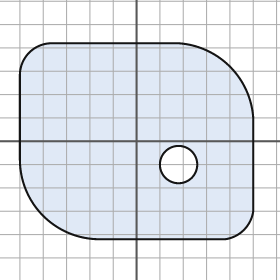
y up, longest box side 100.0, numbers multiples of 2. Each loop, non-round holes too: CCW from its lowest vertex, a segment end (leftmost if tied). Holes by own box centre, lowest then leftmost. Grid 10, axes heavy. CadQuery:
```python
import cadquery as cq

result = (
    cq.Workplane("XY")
    .moveTo(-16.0, -42.0)
    .lineTo(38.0, -42.0)
    .threePointArc((46.0, -38.0), (50.0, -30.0))
    .lineTo(50.0, 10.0)
    .threePointArc((40.0, 32.0), (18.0, 42.0))
    .lineTo(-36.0, 42.0)
    .threePointArc((-46.0, 38.0), (-50.0, 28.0))
    .lineTo(-50.0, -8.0)
    .threePointArc((-40.0, -32.0), (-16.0, -42.0))
    .close()
    .moveTo(18.0, -10.0)
    .circle(8.0)
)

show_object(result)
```